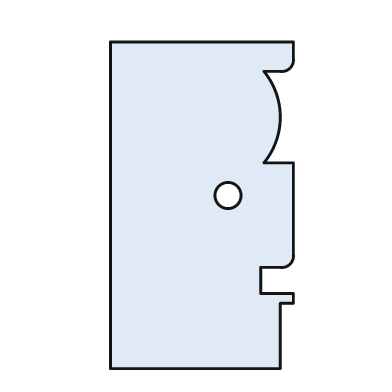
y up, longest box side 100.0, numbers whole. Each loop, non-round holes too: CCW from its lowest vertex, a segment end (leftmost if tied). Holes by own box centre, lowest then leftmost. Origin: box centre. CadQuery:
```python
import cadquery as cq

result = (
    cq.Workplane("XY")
    .moveTo(-28.0, -50.0)
    .lineTo(24.0, -50.0)
    .lineTo(24.0, -30.0)
    .lineTo(28.0, -30.0)
    .lineTo(28.0, -27.0)
    .lineTo(18.0, -27.0)
    .lineTo(18.0, -19.0)
    .lineTo(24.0, -19.0)
    .threePointArc((27.0, -18.0), (28.0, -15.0))
    .lineTo(28.0, 13.0)
    .lineTo(19.0, 13.0)
    .threePointArc((24.0, 27.0), (19.0, 41.0))
    .lineTo(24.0, 41.0)
    .threePointArc((27.0, 42.0), (28.0, 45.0))
    .lineTo(28.0, 50.0)
    .lineTo(-28.0, 50.0)
    .close()
    .moveTo(8.0, 3.0)
    .circle(4.0)
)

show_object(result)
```